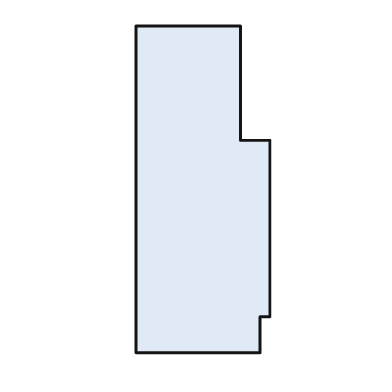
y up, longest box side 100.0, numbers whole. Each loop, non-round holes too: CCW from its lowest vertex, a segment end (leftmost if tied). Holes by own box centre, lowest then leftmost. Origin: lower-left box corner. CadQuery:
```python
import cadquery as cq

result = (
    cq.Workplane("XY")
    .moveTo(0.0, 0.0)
    .lineTo(38.0, 0.0)
    .lineTo(38.0, 11.0)
    .lineTo(41.0, 11.0)
    .lineTo(41.0, 65.0)
    .lineTo(32.0, 65.0)
    .lineTo(32.0, 100.0)
    .lineTo(0.0, 100.0)
    .close()
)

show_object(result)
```